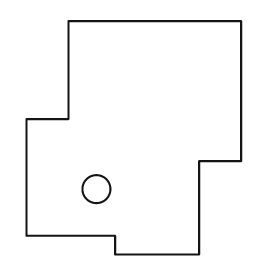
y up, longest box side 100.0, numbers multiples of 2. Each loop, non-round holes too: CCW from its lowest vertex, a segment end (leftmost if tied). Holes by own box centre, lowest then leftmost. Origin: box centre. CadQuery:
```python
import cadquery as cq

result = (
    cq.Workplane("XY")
    .moveTo(-8.0, -50.0)
    .lineTo(28.0, -50.0)
    .lineTo(28.0, -10.0)
    .lineTo(46.0, -10.0)
    .lineTo(46.0, 50.0)
    .lineTo(-28.0, 50.0)
    .lineTo(-28.0, 8.0)
    .lineTo(-46.0, 8.0)
    .lineTo(-46.0, -42.0)
    .lineTo(-8.0, -42.0)
    .close()
    .moveTo(-16.0, -22.0)
    .circle(6.0)
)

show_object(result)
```